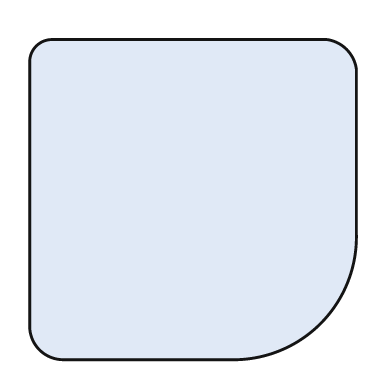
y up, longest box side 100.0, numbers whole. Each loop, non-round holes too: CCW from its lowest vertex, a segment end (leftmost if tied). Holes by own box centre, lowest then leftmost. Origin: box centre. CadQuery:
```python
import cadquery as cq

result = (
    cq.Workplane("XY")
    .moveTo(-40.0, -49.0)
    .lineTo(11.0, -49.0)
    .threePointArc((39.0, -38.0), (50.0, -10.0))
    .lineTo(50.0, 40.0)
    .threePointArc((47.0, 46.0), (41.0, 49.0))
    .lineTo(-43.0, 49.0)
    .threePointArc((-48.0, 47.0), (-50.0, 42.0))
    .lineTo(-50.0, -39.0)
    .threePointArc((-47.0, -46.0), (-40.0, -49.0))
    .close()
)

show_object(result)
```